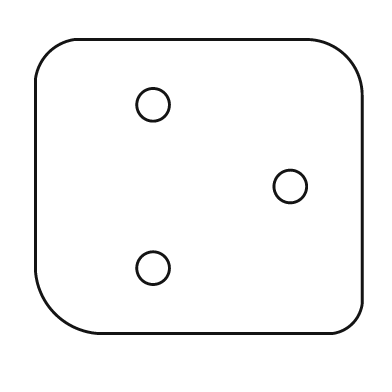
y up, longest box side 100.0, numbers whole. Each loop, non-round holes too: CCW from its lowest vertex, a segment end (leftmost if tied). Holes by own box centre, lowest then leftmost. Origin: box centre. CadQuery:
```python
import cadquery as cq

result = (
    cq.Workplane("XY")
    .moveTo(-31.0, -45.0)
    .lineTo(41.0, -45.0)
    .threePointArc((47.0, -42.0), (50.0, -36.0))
    .lineTo(50.0, 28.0)
    .threePointArc((45.0, 40.0), (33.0, 45.0))
    .lineTo(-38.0, 45.0)
    .threePointArc((-46.0, 41.0), (-50.0, 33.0))
    .lineTo(-50.0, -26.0)
    .threePointArc((-44.0, -39.0), (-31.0, -45.0))
    .close()
    .moveTo(-14.0, -25.0)
    .circle(5.0)
    .moveTo(28.0, 0.0)
    .circle(5.0)
    .moveTo(-14.0, 25.0)
    .circle(5.0)
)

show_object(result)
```